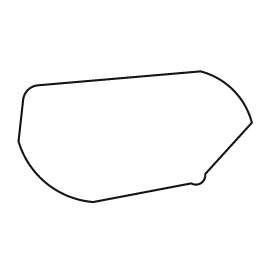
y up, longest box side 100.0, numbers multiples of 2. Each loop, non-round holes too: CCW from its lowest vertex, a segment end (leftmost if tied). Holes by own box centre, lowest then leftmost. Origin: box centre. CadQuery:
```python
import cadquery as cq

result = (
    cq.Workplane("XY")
    .moveTo(-18.0, -28.0)
    .lineTo(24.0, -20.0)
    .threePointArc((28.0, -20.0), (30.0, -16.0))
    .lineTo(50.0, 6.0)
    .threePointArc((42.0, 20.0), (28.0, 28.0))
    .lineTo(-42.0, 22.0)
    .threePointArc((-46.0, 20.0), (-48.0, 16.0))
    .lineTo(-50.0, -2.0)
    .threePointArc((-38.0, -20.0), (-18.0, -28.0))
    .close()
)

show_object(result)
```